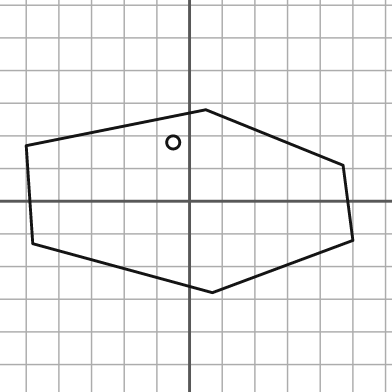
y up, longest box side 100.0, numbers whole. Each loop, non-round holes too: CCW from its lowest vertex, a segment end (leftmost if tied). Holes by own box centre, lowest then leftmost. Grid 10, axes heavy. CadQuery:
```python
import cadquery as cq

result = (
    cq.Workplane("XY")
    .moveTo(7.0, -28.0)
    .lineTo(50.0, -12.0)
    .lineTo(47.0, 11.0)
    .lineTo(5.0, 28.0)
    .lineTo(-50.0, 17.0)
    .lineTo(-48.0, -13.0)
    .close()
    .moveTo(-5.0, 18.0)
    .circle(2.0)
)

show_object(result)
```